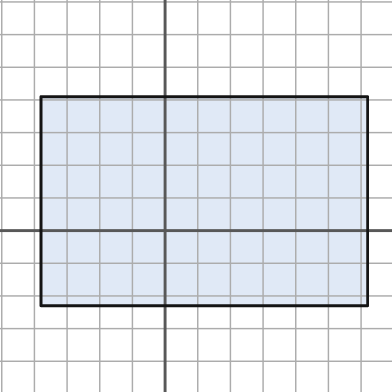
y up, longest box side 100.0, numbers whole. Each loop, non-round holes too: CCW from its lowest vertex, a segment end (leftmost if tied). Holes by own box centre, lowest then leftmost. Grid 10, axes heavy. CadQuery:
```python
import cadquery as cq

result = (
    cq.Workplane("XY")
    .moveTo(-38.0, -23.0)
    .lineTo(62.0, -23.0)
    .lineTo(62.0, 41.0)
    .lineTo(-38.0, 41.0)
    .close()
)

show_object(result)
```